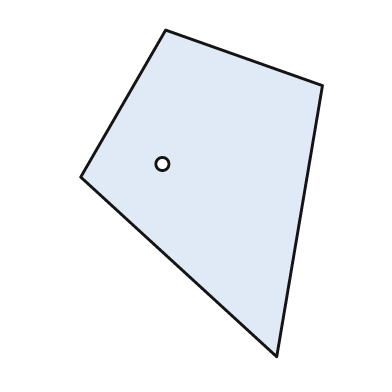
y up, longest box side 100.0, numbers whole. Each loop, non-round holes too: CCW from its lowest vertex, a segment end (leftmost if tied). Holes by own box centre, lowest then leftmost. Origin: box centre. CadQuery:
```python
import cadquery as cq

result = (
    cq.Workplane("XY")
    .moveTo(23.0, -50.0)
    .lineTo(37.0, 33.0)
    .lineTo(-11.0, 50.0)
    .lineTo(-37.0, 5.0)
    .close()
    .moveTo(-12.0, 9.0)
    .circle(2.0)
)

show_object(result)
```